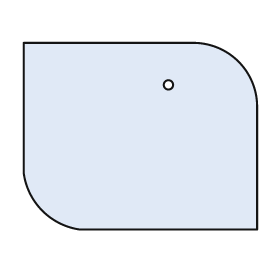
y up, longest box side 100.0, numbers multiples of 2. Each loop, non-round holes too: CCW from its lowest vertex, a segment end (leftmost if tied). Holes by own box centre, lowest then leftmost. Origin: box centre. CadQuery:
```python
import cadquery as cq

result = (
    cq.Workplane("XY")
    .moveTo(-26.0, -40.0)
    .lineTo(50.0, -40.0)
    .lineTo(50.0, 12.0)
    .threePointArc((42.0, 32.0), (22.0, 40.0))
    .lineTo(-50.0, 40.0)
    .lineTo(-50.0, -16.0)
    .threePointArc((-42.0, -32.0), (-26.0, -40.0))
    .close()
    .moveTo(12.0, 22.0)
    .circle(2.0)
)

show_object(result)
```